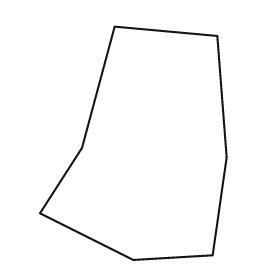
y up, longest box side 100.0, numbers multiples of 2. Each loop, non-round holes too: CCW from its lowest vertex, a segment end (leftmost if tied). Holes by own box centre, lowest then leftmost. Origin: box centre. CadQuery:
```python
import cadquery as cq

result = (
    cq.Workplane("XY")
    .moveTo(0.0, -50.0)
    .lineTo(34.0, -48.0)
    .lineTo(40.0, -6.0)
    .lineTo(36.0, 46.0)
    .lineTo(-8.0, 50.0)
    .lineTo(-22.0, -2.0)
    .lineTo(-40.0, -30.0)
    .close()
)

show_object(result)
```